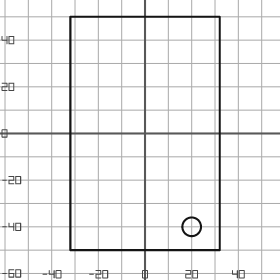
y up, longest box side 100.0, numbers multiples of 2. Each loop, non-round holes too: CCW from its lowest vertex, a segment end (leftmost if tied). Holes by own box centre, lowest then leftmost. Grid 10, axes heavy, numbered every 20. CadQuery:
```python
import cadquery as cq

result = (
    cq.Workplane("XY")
    .moveTo(-32.0, -50.0)
    .lineTo(32.0, -50.0)
    .lineTo(32.0, 50.0)
    .lineTo(-32.0, 50.0)
    .close()
    .moveTo(20.0, -40.0)
    .circle(4.0)
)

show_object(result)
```